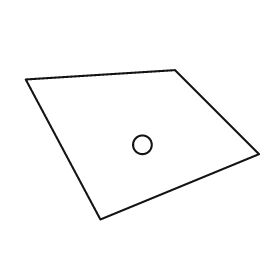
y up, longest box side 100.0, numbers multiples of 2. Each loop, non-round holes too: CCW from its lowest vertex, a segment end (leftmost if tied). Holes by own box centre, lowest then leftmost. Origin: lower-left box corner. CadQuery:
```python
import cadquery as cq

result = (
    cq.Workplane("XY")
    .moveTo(32.0, 0.0)
    .lineTo(100.0, 28.0)
    .lineTo(64.0, 64.0)
    .lineTo(0.0, 60.0)
    .close()
    .moveTo(50.0, 32.0)
    .circle(4.0)
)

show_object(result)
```